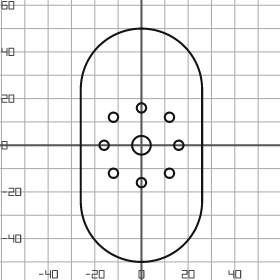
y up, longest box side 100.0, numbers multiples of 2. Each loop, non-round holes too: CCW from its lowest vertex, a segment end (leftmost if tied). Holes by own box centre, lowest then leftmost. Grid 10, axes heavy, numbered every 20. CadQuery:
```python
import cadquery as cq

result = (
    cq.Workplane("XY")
    .moveTo(-26.0, -24.0)
    .threePointArc((0.0, -50.0), (26.0, -24.0))
    .lineTo(26.0, 24.0)
    .threePointArc((0.0, 50.0), (-26.0, 24.0))
    .close()
    .moveTo(0.0, -16.0)
    .circle(2.0)
    .moveTo(-12.0, -12.0)
    .circle(2.0)
    .moveTo(12.0, -12.0)
    .circle(2.0)
    .moveTo(-16.0, 0.0)
    .circle(2.0)
    .moveTo(0.0, 0.0)
    .circle(4.0)
    .moveTo(16.0, 0.0)
    .circle(2.0)
    .moveTo(-12.0, 12.0)
    .circle(2.0)
    .moveTo(12.0, 12.0)
    .circle(2.0)
    .moveTo(0.0, 16.0)
    .circle(2.0)
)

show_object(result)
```